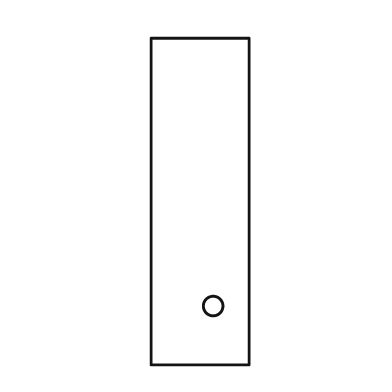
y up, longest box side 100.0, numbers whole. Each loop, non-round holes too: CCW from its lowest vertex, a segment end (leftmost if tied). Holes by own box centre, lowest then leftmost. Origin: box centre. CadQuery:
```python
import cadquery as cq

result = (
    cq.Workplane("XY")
    .moveTo(-15.0, -50.0)
    .lineTo(15.0, -50.0)
    .lineTo(15.0, 50.0)
    .lineTo(-15.0, 50.0)
    .close()
    .moveTo(4.0, -32.0)
    .circle(3.0)
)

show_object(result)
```